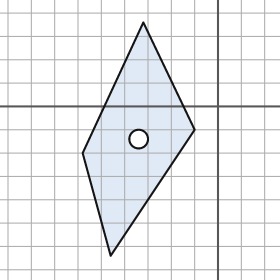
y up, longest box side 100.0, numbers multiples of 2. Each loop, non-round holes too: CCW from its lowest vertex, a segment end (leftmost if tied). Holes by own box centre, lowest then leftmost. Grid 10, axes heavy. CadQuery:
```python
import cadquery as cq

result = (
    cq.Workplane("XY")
    .moveTo(-46.0, -64.0)
    .lineTo(-10.0, -10.0)
    .lineTo(-32.0, 36.0)
    .lineTo(-58.0, -20.0)
    .close()
    .moveTo(-34.0, -14.0)
    .circle(4.0)
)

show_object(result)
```